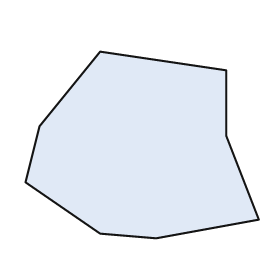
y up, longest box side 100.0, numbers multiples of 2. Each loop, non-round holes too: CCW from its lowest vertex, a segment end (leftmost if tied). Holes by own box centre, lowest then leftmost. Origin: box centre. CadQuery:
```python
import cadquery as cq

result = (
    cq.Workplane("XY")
    .moveTo(6.0, -40.0)
    .lineTo(50.0, -32.0)
    .lineTo(36.0, 4.0)
    .lineTo(36.0, 32.0)
    .lineTo(-18.0, 40.0)
    .lineTo(-44.0, 8.0)
    .lineTo(-50.0, -16.0)
    .lineTo(-18.0, -38.0)
    .close()
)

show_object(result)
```